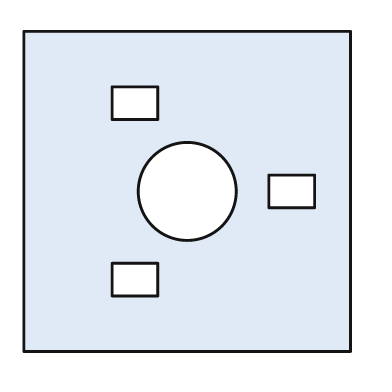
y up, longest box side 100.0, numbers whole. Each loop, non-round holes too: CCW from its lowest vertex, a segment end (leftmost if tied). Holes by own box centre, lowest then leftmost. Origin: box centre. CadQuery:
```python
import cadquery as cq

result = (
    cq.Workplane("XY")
    .moveTo(-50.0, -49.0)
    .lineTo(50.0, -49.0)
    .lineTo(50.0, 49.0)
    .lineTo(-50.0, 49.0)
    .close()
    .moveTo(-23.0, -32.0)
    .lineTo(-9.0, -32.0)
    .lineTo(-9.0, -22.0)
    .lineTo(-23.0, -22.0)
    .close()
    .moveTo(0.0, 0.0)
    .circle(15.0)
    .moveTo(25.0, -5.0)
    .lineTo(39.0, -5.0)
    .lineTo(39.0, 5.0)
    .lineTo(25.0, 5.0)
    .close()
    .moveTo(-23.0, 22.0)
    .lineTo(-9.0, 22.0)
    .lineTo(-9.0, 32.0)
    .lineTo(-23.0, 32.0)
    .close()
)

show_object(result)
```